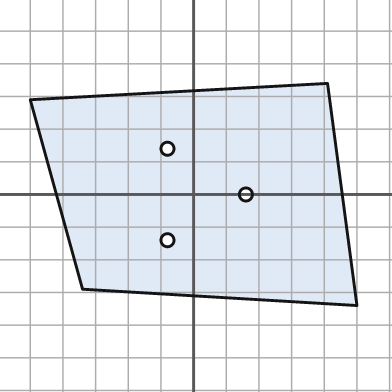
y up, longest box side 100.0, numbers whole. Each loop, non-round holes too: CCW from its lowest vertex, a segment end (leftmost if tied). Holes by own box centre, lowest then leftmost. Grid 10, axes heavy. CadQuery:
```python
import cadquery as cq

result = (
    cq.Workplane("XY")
    .moveTo(50.0, -34.0)
    .lineTo(41.0, 34.0)
    .lineTo(-50.0, 29.0)
    .lineTo(-34.0, -29.0)
    .close()
    .moveTo(-8.0, -14.0)
    .circle(2.0)
    .moveTo(16.0, 0.0)
    .circle(2.0)
    .moveTo(-8.0, 14.0)
    .circle(2.0)
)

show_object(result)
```